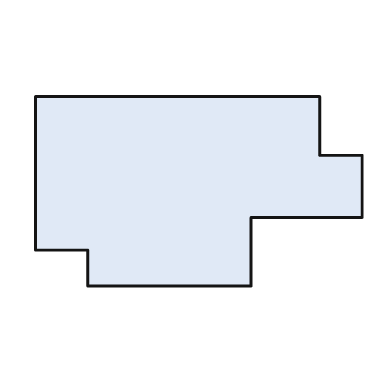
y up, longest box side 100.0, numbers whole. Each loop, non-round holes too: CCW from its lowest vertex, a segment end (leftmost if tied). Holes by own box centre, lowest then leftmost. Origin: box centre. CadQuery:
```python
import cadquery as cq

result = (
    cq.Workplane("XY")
    .moveTo(-34.0, -29.0)
    .lineTo(16.0, -29.0)
    .lineTo(16.0, -8.0)
    .lineTo(50.0, -8.0)
    .lineTo(50.0, 11.0)
    .lineTo(37.0, 11.0)
    .lineTo(37.0, 29.0)
    .lineTo(-50.0, 29.0)
    .lineTo(-50.0, -18.0)
    .lineTo(-34.0, -18.0)
    .close()
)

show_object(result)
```